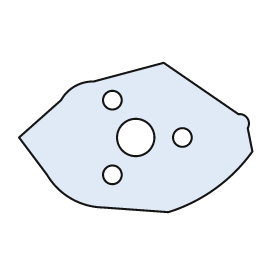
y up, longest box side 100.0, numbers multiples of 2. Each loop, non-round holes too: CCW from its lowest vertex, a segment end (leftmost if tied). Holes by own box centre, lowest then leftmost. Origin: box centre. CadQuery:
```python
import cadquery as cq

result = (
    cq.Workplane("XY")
    .moveTo(14.0, -32.0)
    .threePointArc((34.0, -22.0), (50.0, -6.0))
    .lineTo(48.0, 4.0)
    .threePointArc((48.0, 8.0), (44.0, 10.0))
    .lineTo(12.0, 32.0)
    .lineTo(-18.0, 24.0)
    .threePointArc((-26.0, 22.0), (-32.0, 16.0))
    .lineTo(-50.0, 0.0)
    .lineTo(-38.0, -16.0)
    .threePointArc((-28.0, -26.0), (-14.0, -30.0))
    .close()
    .moveTo(-10.0, -16.0)
    .circle(4.0)
    .moveTo(0.0, 0.0)
    .circle(8.0)
    .moveTo(20.0, 0.0)
    .circle(4.0)
    .moveTo(-10.0, 16.0)
    .circle(4.0)
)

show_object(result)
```